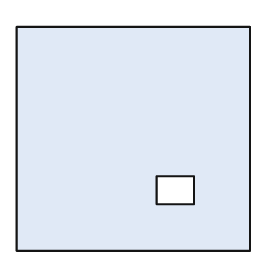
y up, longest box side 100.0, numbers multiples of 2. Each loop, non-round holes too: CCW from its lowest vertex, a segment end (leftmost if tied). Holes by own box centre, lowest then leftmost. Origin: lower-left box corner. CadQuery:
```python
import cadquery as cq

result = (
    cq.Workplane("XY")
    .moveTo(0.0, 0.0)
    .lineTo(100.0, 0.0)
    .lineTo(100.0, 96.0)
    .lineTo(0.0, 96.0)
    .close()
    .moveTo(60.0, 20.0)
    .lineTo(76.0, 20.0)
    .lineTo(76.0, 32.0)
    .lineTo(60.0, 32.0)
    .close()
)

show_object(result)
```